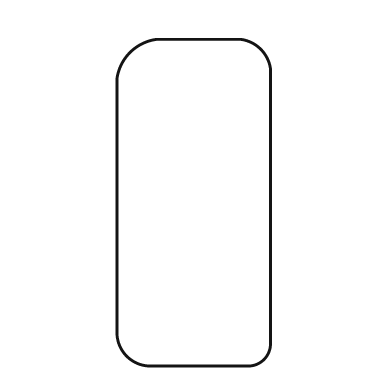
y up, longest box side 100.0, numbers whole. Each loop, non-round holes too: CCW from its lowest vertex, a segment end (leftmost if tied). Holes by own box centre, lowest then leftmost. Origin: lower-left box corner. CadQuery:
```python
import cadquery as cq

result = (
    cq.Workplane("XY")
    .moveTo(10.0, 0.0)
    .lineTo(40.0, 0.0)
    .threePointArc((45.0, 2.0), (47.0, 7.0))
    .lineTo(47.0, 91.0)
    .threePointArc((44.0, 97.0), (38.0, 100.0))
    .lineTo(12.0, 100.0)
    .threePointArc((4.0, 96.0), (0.0, 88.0))
    .lineTo(0.0, 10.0)
    .threePointArc((3.0, 3.0), (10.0, 0.0))
    .close()
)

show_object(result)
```